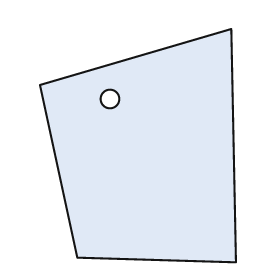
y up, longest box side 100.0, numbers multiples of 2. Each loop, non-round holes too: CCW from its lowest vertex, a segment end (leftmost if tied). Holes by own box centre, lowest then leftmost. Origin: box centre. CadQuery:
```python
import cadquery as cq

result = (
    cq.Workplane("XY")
    .moveTo(42.0, -50.0)
    .lineTo(40.0, 50.0)
    .lineTo(-42.0, 26.0)
    .lineTo(-26.0, -48.0)
    .close()
    .moveTo(-12.0, 20.0)
    .circle(4.0)
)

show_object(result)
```